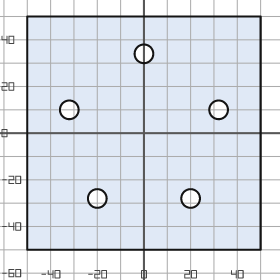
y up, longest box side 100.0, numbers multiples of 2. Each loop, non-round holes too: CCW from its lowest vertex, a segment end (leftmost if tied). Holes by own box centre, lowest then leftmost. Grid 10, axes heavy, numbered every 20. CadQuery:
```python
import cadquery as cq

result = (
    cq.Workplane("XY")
    .moveTo(-50.0, -50.0)
    .lineTo(50.0, -50.0)
    .lineTo(50.0, 50.0)
    .lineTo(-50.0, 50.0)
    .close()
    .moveTo(-20.0, -28.0)
    .circle(4.0)
    .moveTo(20.0, -28.0)
    .circle(4.0)
    .moveTo(-32.0, 10.0)
    .circle(4.0)
    .moveTo(32.0, 10.0)
    .circle(4.0)
    .moveTo(0.0, 34.0)
    .circle(4.0)
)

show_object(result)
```